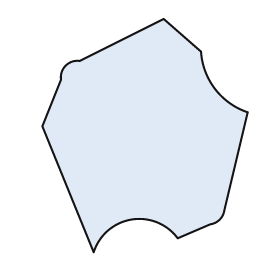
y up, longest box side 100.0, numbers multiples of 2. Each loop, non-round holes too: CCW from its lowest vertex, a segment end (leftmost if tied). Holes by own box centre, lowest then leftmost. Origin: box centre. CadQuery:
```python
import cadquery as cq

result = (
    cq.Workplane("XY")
    .moveTo(-22.0, -50.0)
    .threePointArc((-6.0, -36.0), (14.0, -44.0))
    .lineTo(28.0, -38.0)
    .threePointArc((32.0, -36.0), (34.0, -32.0))
    .lineTo(44.0, 10.0)
    .threePointArc((30.0, 20.0), (24.0, 36.0))
    .lineTo(8.0, 50.0)
    .lineTo(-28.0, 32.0)
    .threePointArc((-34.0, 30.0), (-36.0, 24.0))
    .lineTo(-44.0, 4.0)
    .close()
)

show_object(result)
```